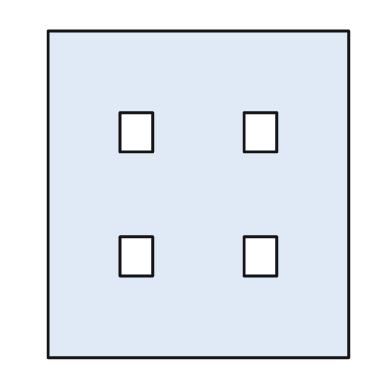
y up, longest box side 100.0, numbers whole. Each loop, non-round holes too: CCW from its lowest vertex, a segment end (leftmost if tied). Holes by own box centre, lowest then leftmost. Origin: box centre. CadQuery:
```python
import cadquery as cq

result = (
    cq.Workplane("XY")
    .moveTo(-46.0, -50.0)
    .lineTo(46.0, -50.0)
    .lineTo(46.0, 50.0)
    .lineTo(-46.0, 50.0)
    .close()
    .moveTo(-24.0, -25.0)
    .lineTo(-14.0, -25.0)
    .lineTo(-14.0, -13.0)
    .lineTo(-24.0, -13.0)
    .close()
    .moveTo(14.0, -25.0)
    .lineTo(24.0, -25.0)
    .lineTo(24.0, -13.0)
    .lineTo(14.0, -13.0)
    .close()
    .moveTo(-24.0, 13.0)
    .lineTo(-14.0, 13.0)
    .lineTo(-14.0, 25.0)
    .lineTo(-24.0, 25.0)
    .close()
    .moveTo(14.0, 13.0)
    .lineTo(24.0, 13.0)
    .lineTo(24.0, 25.0)
    .lineTo(14.0, 25.0)
    .close()
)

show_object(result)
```